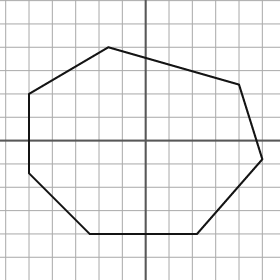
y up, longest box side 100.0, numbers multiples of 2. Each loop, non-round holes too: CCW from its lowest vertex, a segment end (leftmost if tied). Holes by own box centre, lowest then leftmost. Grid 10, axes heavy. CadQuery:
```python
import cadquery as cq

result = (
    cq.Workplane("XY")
    .moveTo(-24.0, -40.0)
    .lineTo(22.0, -40.0)
    .lineTo(50.0, -8.0)
    .lineTo(40.0, 24.0)
    .lineTo(-16.0, 40.0)
    .lineTo(-50.0, 20.0)
    .lineTo(-50.0, -14.0)
    .close()
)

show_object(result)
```